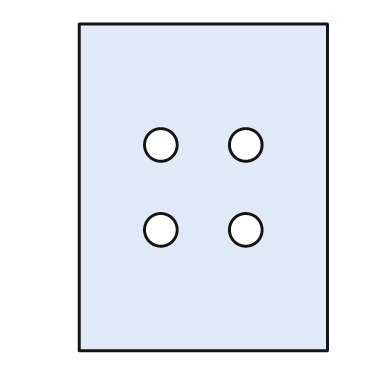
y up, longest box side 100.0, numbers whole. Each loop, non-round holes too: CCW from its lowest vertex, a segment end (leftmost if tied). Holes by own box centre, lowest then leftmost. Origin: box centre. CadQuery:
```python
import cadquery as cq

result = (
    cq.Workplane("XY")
    .moveTo(-38.0, -50.0)
    .lineTo(38.0, -50.0)
    .lineTo(38.0, 50.0)
    .lineTo(-38.0, 50.0)
    .close()
    .moveTo(-13.0, -13.0)
    .circle(5.0)
    .moveTo(13.0, -13.0)
    .circle(5.0)
    .moveTo(-13.0, 13.0)
    .circle(5.0)
    .moveTo(13.0, 13.0)
    .circle(5.0)
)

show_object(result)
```